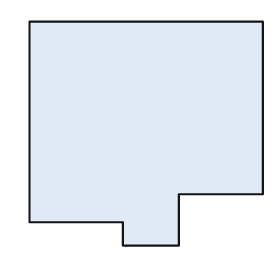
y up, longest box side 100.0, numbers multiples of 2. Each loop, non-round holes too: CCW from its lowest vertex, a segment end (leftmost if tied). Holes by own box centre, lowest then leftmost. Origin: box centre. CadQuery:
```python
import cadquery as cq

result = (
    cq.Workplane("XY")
    .moveTo(-10.0, -48.0)
    .lineTo(14.0, -48.0)
    .lineTo(14.0, -26.0)
    .lineTo(50.0, -26.0)
    .lineTo(50.0, 48.0)
    .lineTo(-50.0, 48.0)
    .lineTo(-50.0, -38.0)
    .lineTo(-10.0, -38.0)
    .close()
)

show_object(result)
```